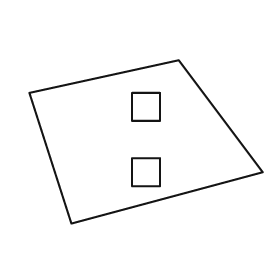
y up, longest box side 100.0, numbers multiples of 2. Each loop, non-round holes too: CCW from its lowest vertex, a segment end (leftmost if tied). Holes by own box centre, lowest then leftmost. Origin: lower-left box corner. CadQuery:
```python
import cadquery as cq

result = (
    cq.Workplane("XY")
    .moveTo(18.0, 0.0)
    .lineTo(100.0, 22.0)
    .lineTo(64.0, 70.0)
    .lineTo(0.0, 56.0)
    .close()
    .moveTo(44.0, 16.0)
    .lineTo(56.0, 16.0)
    .lineTo(56.0, 28.0)
    .lineTo(44.0, 28.0)
    .close()
    .moveTo(44.0, 44.0)
    .lineTo(56.0, 44.0)
    .lineTo(56.0, 56.0)
    .lineTo(44.0, 56.0)
    .close()
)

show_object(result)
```